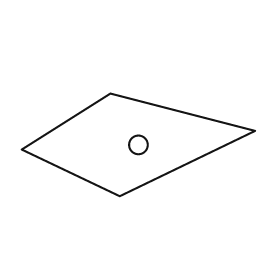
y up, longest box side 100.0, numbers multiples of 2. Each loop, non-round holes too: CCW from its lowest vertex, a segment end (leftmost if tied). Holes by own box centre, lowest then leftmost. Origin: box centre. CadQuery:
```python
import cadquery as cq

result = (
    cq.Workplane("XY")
    .moveTo(-8.0, -22.0)
    .lineTo(50.0, 6.0)
    .lineTo(-12.0, 22.0)
    .lineTo(-50.0, -2.0)
    .close()
    .moveTo(0.0, 0.0)
    .circle(4.0)
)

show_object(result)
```